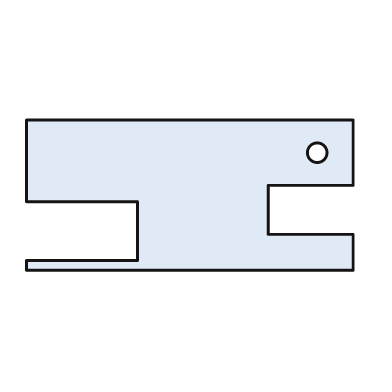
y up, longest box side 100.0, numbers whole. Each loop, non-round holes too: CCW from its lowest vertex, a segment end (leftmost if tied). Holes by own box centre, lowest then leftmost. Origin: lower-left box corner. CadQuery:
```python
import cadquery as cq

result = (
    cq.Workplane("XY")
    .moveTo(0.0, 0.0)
    .lineTo(100.0, 0.0)
    .lineTo(100.0, 11.0)
    .lineTo(74.0, 11.0)
    .lineTo(74.0, 26.0)
    .lineTo(100.0, 26.0)
    .lineTo(100.0, 46.0)
    .lineTo(0.0, 46.0)
    .lineTo(0.0, 21.0)
    .lineTo(34.0, 21.0)
    .lineTo(34.0, 3.0)
    .lineTo(0.0, 3.0)
    .close()
    .moveTo(89.0, 36.0)
    .circle(3.0)
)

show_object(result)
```